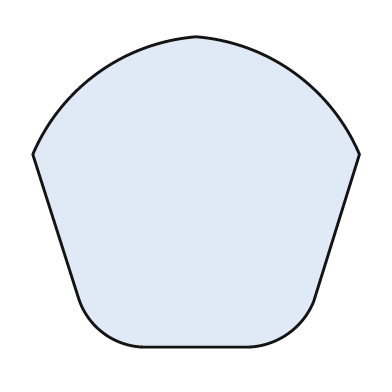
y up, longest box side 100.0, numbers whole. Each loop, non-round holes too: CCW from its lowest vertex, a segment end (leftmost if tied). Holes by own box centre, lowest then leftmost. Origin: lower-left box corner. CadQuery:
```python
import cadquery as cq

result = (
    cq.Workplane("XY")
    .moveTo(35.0, 0.0)
    .lineTo(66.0, 0.0)
    .threePointArc((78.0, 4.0), (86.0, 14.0))
    .lineTo(100.0, 59.0)
    .threePointArc((80.0, 84.0), (50.0, 95.0))
    .threePointArc((20.0, 84.0), (0.0, 59.0))
    .lineTo(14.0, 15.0)
    .threePointArc((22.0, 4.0), (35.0, 0.0))
    .close()
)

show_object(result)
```